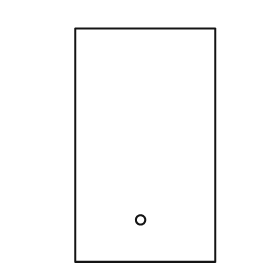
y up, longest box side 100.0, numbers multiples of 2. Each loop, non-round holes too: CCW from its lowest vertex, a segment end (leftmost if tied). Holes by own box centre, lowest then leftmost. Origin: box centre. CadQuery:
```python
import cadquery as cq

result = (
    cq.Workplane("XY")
    .moveTo(-30.0, -50.0)
    .lineTo(30.0, -50.0)
    .lineTo(30.0, 50.0)
    .lineTo(-30.0, 50.0)
    .close()
    .moveTo(-2.0, -32.0)
    .circle(2.0)
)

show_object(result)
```